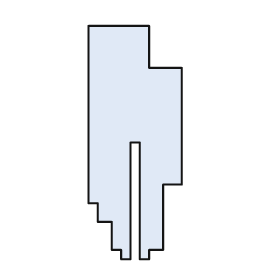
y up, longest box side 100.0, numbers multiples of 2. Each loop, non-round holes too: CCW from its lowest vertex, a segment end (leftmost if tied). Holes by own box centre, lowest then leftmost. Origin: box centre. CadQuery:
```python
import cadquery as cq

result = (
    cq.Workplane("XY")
    .moveTo(-6.0, -50.0)
    .lineTo(-2.0, -50.0)
    .lineTo(-2.0, 0.0)
    .lineTo(2.0, 0.0)
    .lineTo(2.0, -50.0)
    .lineTo(6.0, -50.0)
    .lineTo(6.0, -46.0)
    .lineTo(12.0, -46.0)
    .lineTo(12.0, -18.0)
    .lineTo(20.0, -18.0)
    .lineTo(20.0, 32.0)
    .lineTo(6.0, 32.0)
    .lineTo(6.0, 50.0)
    .lineTo(-20.0, 50.0)
    .lineTo(-20.0, -26.0)
    .lineTo(-16.0, -26.0)
    .lineTo(-16.0, -34.0)
    .lineTo(-10.0, -34.0)
    .lineTo(-10.0, -46.0)
    .lineTo(-6.0, -46.0)
    .close()
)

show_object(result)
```